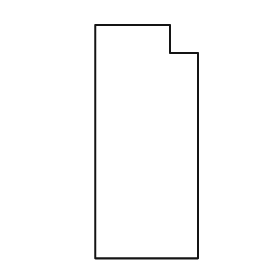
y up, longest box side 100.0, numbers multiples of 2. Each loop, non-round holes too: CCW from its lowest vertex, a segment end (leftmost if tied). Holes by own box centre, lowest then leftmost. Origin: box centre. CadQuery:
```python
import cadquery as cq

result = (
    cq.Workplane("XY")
    .moveTo(-22.0, -50.0)
    .lineTo(22.0, -50.0)
    .lineTo(22.0, 38.0)
    .lineTo(10.0, 38.0)
    .lineTo(10.0, 50.0)
    .lineTo(-22.0, 50.0)
    .close()
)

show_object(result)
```